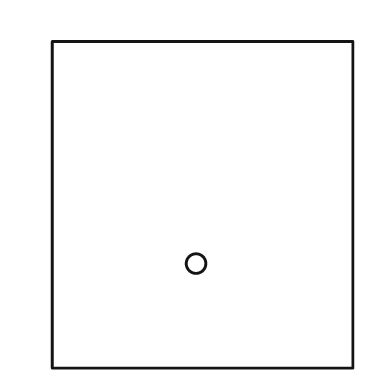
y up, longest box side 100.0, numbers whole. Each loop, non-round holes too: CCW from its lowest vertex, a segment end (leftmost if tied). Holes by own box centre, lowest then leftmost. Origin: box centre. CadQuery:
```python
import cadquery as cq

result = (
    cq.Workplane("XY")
    .moveTo(-46.0, -50.0)
    .lineTo(46.0, -50.0)
    .lineTo(46.0, 50.0)
    .lineTo(-46.0, 50.0)
    .close()
    .moveTo(-2.0, -18.0)
    .circle(3.0)
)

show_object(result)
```